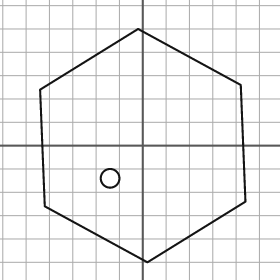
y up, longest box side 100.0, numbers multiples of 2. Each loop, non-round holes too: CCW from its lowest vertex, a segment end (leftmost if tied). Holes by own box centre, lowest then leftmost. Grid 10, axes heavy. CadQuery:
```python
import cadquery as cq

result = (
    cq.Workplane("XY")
    .moveTo(2.0, -50.0)
    .lineTo(44.0, -24.0)
    .lineTo(42.0, 26.0)
    .lineTo(-2.0, 50.0)
    .lineTo(-44.0, 24.0)
    .lineTo(-42.0, -26.0)
    .close()
    .moveTo(-14.0, -14.0)
    .circle(4.0)
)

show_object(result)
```